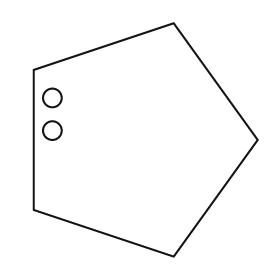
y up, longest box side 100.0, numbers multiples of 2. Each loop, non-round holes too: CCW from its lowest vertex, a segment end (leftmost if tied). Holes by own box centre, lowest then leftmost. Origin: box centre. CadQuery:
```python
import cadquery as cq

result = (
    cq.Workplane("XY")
    .moveTo(12.0, -50.0)
    .lineTo(48.0, 0.0)
    .lineTo(12.0, 50.0)
    .lineTo(-48.0, 30.0)
    .lineTo(-48.0, -30.0)
    .close()
    .moveTo(-40.0, 4.0)
    .circle(4.0)
    .moveTo(-40.0, 18.0)
    .circle(4.0)
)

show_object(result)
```